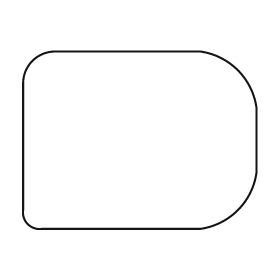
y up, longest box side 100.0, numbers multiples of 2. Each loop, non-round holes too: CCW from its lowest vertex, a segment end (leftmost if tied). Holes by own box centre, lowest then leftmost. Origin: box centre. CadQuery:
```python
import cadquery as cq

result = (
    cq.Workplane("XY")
    .moveTo(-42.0, -38.0)
    .lineTo(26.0, -38.0)
    .threePointArc((42.0, -30.0), (50.0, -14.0))
    .lineTo(50.0, 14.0)
    .threePointArc((42.0, 30.0), (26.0, 38.0))
    .lineTo(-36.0, 38.0)
    .threePointArc((-46.0, 34.0), (-50.0, 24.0))
    .lineTo(-50.0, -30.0)
    .threePointArc((-48.0, -36.0), (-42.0, -38.0))
    .close()
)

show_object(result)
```